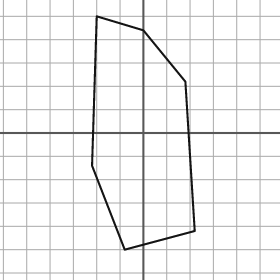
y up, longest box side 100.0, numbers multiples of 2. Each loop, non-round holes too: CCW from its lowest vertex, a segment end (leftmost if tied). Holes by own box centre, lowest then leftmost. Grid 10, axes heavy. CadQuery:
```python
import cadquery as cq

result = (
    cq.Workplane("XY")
    .moveTo(-8.0, -50.0)
    .lineTo(22.0, -42.0)
    .lineTo(18.0, 22.0)
    .lineTo(0.0, 44.0)
    .lineTo(-20.0, 50.0)
    .lineTo(-22.0, -14.0)
    .close()
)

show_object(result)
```